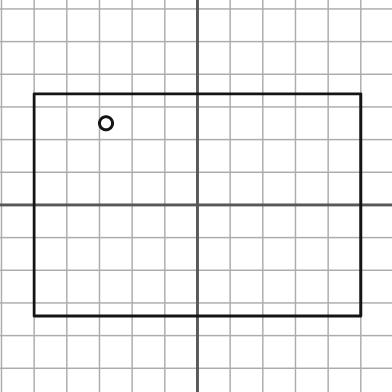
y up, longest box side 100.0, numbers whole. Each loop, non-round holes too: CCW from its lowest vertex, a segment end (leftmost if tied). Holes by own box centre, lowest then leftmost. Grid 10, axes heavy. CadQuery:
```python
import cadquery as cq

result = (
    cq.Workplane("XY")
    .moveTo(-50.0, -34.0)
    .lineTo(50.0, -34.0)
    .lineTo(50.0, 34.0)
    .lineTo(-50.0, 34.0)
    .close()
    .moveTo(-28.0, 25.0)
    .circle(2.0)
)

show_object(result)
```